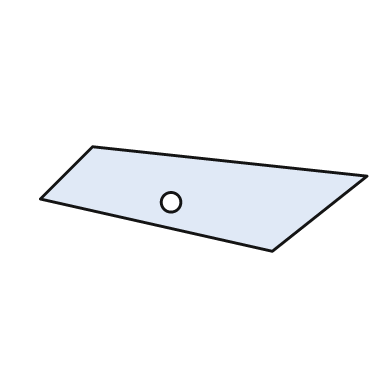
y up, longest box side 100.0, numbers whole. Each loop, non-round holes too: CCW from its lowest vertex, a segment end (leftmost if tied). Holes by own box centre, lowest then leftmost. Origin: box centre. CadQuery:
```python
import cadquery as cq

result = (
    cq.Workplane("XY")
    .moveTo(21.0, -16.0)
    .lineTo(50.0, 7.0)
    .lineTo(-34.0, 16.0)
    .lineTo(-50.0, 0.0)
    .close()
    .moveTo(-10.0, -1.0)
    .circle(3.0)
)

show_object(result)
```